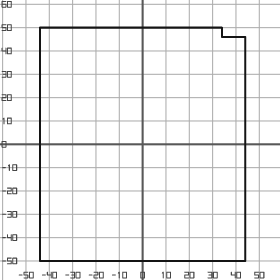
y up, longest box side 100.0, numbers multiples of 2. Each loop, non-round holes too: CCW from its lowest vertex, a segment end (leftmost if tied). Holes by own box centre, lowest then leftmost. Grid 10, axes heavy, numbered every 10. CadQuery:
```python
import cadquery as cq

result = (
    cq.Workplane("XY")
    .moveTo(-44.0, -50.0)
    .lineTo(44.0, -50.0)
    .lineTo(44.0, 46.0)
    .lineTo(34.0, 46.0)
    .lineTo(34.0, 50.0)
    .lineTo(-44.0, 50.0)
    .close()
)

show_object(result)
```